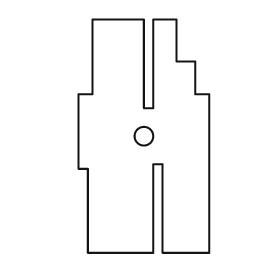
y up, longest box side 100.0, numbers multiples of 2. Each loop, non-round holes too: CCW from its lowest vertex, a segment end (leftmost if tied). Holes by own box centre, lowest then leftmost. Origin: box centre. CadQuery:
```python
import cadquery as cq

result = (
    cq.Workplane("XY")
    .moveTo(-24.0, -50.0)
    .lineTo(4.0, -50.0)
    .lineTo(4.0, -12.0)
    .lineTo(8.0, -12.0)
    .lineTo(8.0, -50.0)
    .lineTo(28.0, -50.0)
    .lineTo(28.0, 18.0)
    .lineTo(22.0, 18.0)
    .lineTo(22.0, 32.0)
    .lineTo(14.0, 32.0)
    .lineTo(14.0, 50.0)
    .lineTo(4.0, 50.0)
    .lineTo(4.0, 12.0)
    .lineTo(0.0, 12.0)
    .lineTo(0.0, 50.0)
    .lineTo(-22.0, 50.0)
    .lineTo(-22.0, 18.0)
    .lineTo(-28.0, 18.0)
    .lineTo(-28.0, -14.0)
    .lineTo(-24.0, -14.0)
    .close()
    .moveTo(0.0, 0.0)
    .circle(4.0)
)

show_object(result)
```